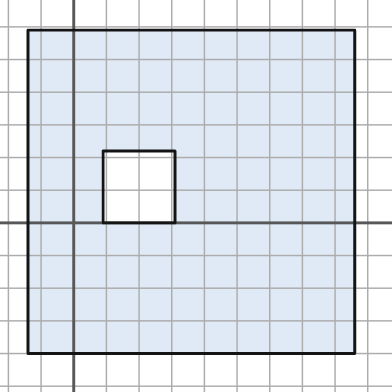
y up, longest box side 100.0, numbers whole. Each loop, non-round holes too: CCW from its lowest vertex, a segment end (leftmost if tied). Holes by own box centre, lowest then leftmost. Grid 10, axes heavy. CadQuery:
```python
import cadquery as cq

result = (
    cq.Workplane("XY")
    .moveTo(-14.0, -40.0)
    .lineTo(86.0, -40.0)
    .lineTo(86.0, 59.0)
    .lineTo(-14.0, 59.0)
    .close()
    .moveTo(9.0, 0.0)
    .lineTo(31.0, 0.0)
    .lineTo(31.0, 22.0)
    .lineTo(9.0, 22.0)
    .close()
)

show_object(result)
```